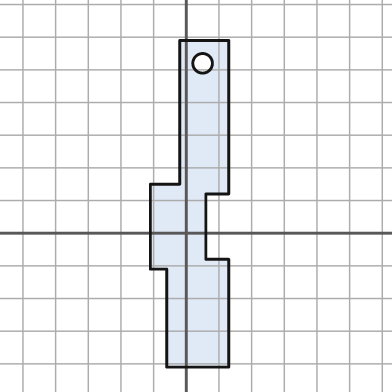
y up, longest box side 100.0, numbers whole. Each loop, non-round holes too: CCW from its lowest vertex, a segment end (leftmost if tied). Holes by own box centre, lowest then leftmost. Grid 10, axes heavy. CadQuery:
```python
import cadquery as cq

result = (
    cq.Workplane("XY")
    .moveTo(-6.0, -41.0)
    .lineTo(13.0, -41.0)
    .lineTo(13.0, -8.0)
    .lineTo(6.0, -8.0)
    .lineTo(6.0, 12.0)
    .lineTo(13.0, 12.0)
    .lineTo(13.0, 59.0)
    .lineTo(-2.0, 59.0)
    .lineTo(-2.0, 15.0)
    .lineTo(-11.0, 15.0)
    .lineTo(-11.0, -11.0)
    .lineTo(-6.0, -11.0)
    .close()
    .moveTo(5.0, 52.0)
    .circle(3.0)
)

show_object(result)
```